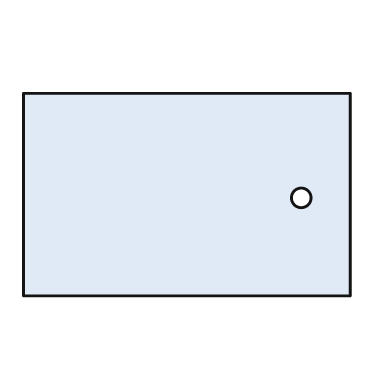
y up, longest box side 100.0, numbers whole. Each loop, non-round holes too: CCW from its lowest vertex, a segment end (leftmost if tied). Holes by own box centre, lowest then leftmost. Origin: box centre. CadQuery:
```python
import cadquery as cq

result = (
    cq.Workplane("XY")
    .moveTo(-50.0, -31.0)
    .lineTo(50.0, -31.0)
    .lineTo(50.0, 31.0)
    .lineTo(-50.0, 31.0)
    .close()
    .moveTo(35.0, -1.0)
    .circle(3.0)
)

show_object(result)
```